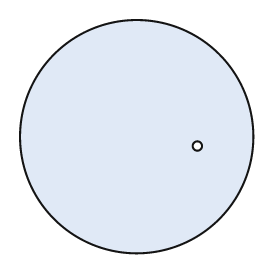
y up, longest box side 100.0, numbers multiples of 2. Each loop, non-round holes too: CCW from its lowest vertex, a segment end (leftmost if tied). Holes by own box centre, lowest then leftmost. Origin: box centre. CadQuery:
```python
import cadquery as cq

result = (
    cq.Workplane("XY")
    .moveTo(0.0, 0.0)
    .circle(50.0)
    .moveTo(26.0, -4.0)
    .circle(2.0)
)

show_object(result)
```